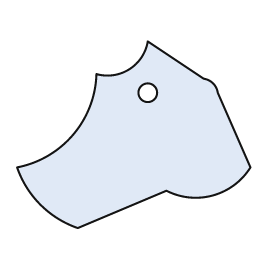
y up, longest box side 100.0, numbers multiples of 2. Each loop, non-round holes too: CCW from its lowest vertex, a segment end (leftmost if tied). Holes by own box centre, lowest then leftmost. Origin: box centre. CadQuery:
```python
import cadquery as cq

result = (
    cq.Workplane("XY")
    .moveTo(-24.0, -40.0)
    .lineTo(14.0, -24.0)
    .threePointArc((34.0, -26.0), (50.0, -14.0))
    .lineTo(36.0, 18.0)
    .threePointArc((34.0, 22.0), (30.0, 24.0))
    .lineTo(6.0, 40.0)
    .threePointArc((-2.0, 28.0), (-16.0, 26.0))
    .threePointArc((-26.0, 0.0), (-50.0, -14.0))
    .threePointArc((-40.0, -30.0), (-24.0, -40.0))
    .close()
    .moveTo(6.0, 18.0)
    .circle(4.0)
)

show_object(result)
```